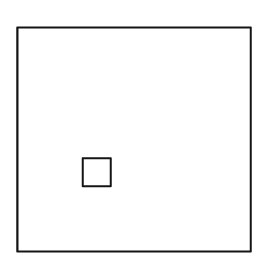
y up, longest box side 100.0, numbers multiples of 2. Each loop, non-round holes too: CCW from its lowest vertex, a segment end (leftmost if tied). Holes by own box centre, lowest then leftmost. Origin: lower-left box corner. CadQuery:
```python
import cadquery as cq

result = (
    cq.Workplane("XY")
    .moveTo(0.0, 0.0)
    .lineTo(100.0, 0.0)
    .lineTo(100.0, 96.0)
    .lineTo(0.0, 96.0)
    .close()
    .moveTo(28.0, 28.0)
    .lineTo(40.0, 28.0)
    .lineTo(40.0, 40.0)
    .lineTo(28.0, 40.0)
    .close()
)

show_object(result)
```